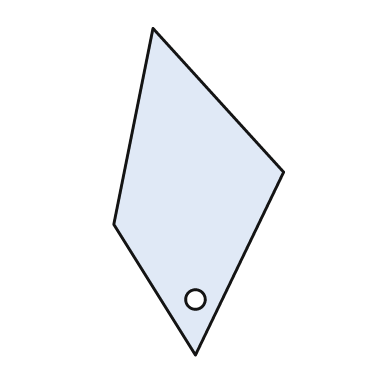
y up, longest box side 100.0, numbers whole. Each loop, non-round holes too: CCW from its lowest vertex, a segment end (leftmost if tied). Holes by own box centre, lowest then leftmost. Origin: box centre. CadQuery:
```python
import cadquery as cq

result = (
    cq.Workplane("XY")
    .moveTo(-1.0, -50.0)
    .lineTo(26.0, 6.0)
    .lineTo(-14.0, 50.0)
    .lineTo(-26.0, -10.0)
    .close()
    .moveTo(-1.0, -33.0)
    .circle(3.0)
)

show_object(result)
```